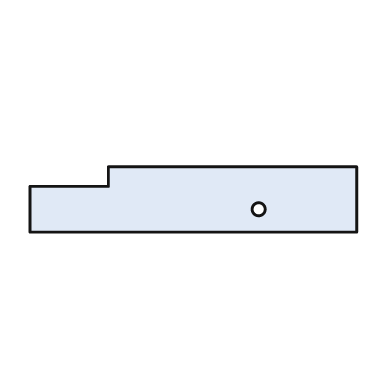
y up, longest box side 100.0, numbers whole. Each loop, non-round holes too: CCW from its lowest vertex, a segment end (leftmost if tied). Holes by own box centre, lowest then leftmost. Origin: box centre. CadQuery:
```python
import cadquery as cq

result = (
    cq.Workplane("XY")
    .moveTo(-50.0, -10.0)
    .lineTo(50.0, -10.0)
    .lineTo(50.0, 10.0)
    .lineTo(-26.0, 10.0)
    .lineTo(-26.0, 4.0)
    .lineTo(-50.0, 4.0)
    .close()
    .moveTo(20.0, -3.0)
    .circle(2.0)
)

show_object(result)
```